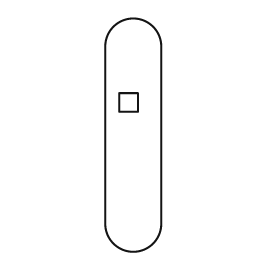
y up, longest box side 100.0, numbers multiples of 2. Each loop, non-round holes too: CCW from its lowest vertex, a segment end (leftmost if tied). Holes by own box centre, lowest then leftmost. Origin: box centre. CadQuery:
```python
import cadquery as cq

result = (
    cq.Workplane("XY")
    .moveTo(-12.0, -38.0)
    .threePointArc((0.0, -50.0), (12.0, -38.0))
    .lineTo(12.0, 38.0)
    .threePointArc((0.0, 50.0), (-12.0, 38.0))
    .close()
    .moveTo(-6.0, 10.0)
    .lineTo(2.0, 10.0)
    .lineTo(2.0, 18.0)
    .lineTo(-6.0, 18.0)
    .close()
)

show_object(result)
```